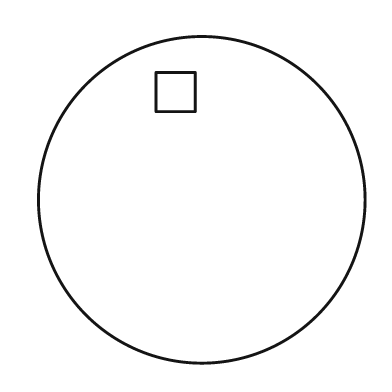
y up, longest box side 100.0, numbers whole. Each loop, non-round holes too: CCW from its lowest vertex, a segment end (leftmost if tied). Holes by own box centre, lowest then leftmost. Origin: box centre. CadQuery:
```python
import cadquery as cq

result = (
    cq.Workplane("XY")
    .moveTo(0.0, 0.0)
    .circle(50.0)
    .moveTo(-14.0, 27.0)
    .lineTo(-2.0, 27.0)
    .lineTo(-2.0, 39.0)
    .lineTo(-14.0, 39.0)
    .close()
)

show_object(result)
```